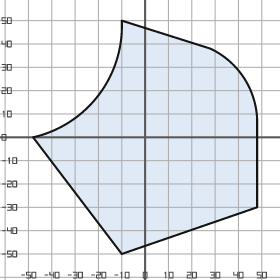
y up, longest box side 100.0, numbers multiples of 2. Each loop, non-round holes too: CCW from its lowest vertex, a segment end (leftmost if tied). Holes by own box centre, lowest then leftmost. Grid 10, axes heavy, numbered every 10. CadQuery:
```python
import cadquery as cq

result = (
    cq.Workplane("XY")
    .moveTo(-10.0, -50.0)
    .lineTo(48.0, -30.0)
    .lineTo(48.0, 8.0)
    .threePointArc((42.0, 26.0), (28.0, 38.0))
    .lineTo(-10.0, 50.0)
    .threePointArc((-20.0, 18.0), (-48.0, 0.0))
    .close()
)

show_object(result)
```